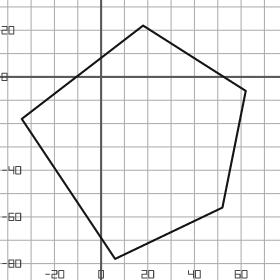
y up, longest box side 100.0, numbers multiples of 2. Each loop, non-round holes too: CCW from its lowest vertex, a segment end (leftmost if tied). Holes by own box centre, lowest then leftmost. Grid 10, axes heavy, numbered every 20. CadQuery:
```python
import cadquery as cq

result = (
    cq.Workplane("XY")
    .moveTo(6.0, -78.0)
    .lineTo(52.0, -56.0)
    .lineTo(62.0, -6.0)
    .lineTo(18.0, 22.0)
    .lineTo(-34.0, -18.0)
    .close()
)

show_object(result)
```